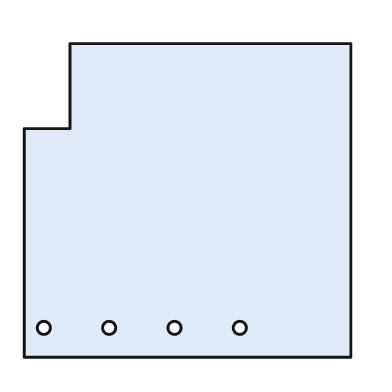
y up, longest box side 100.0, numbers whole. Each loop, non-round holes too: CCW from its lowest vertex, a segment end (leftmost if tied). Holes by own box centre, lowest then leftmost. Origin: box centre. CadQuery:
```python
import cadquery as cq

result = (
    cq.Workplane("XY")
    .moveTo(-50.0, -48.0)
    .lineTo(50.0, -48.0)
    .lineTo(50.0, 48.0)
    .lineTo(-36.0, 48.0)
    .lineTo(-36.0, 22.0)
    .lineTo(-50.0, 22.0)
    .close()
    .moveTo(-44.0, -39.0)
    .circle(2.0)
    .moveTo(-24.0, -39.0)
    .circle(2.0)
    .moveTo(-4.0, -39.0)
    .circle(2.0)
    .moveTo(16.0, -39.0)
    .circle(2.0)
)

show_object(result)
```